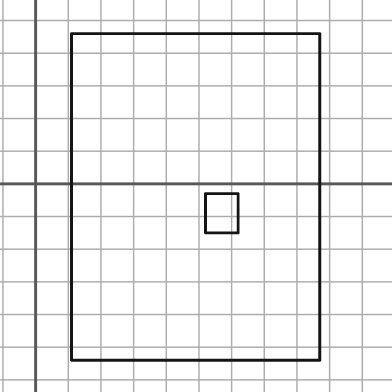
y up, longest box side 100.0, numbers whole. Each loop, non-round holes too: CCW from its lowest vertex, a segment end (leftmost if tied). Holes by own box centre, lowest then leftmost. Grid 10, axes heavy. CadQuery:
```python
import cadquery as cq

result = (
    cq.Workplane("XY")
    .moveTo(11.0, -54.0)
    .lineTo(87.0, -54.0)
    .lineTo(87.0, 46.0)
    .lineTo(11.0, 46.0)
    .close()
    .moveTo(52.0, -15.0)
    .lineTo(62.0, -15.0)
    .lineTo(62.0, -3.0)
    .lineTo(52.0, -3.0)
    .close()
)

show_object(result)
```